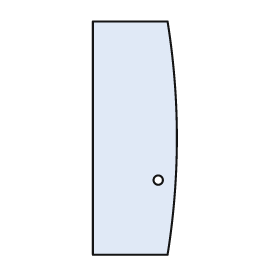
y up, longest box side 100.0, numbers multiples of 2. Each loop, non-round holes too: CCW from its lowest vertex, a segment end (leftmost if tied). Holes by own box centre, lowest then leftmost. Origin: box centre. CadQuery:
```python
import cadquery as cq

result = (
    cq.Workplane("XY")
    .moveTo(-18.0, -50.0)
    .lineTo(14.0, -50.0)
    .threePointArc((18.0, 0.0), (14.0, 50.0))
    .lineTo(-18.0, 50.0)
    .close()
    .moveTo(10.0, -18.0)
    .circle(2.0)
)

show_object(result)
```